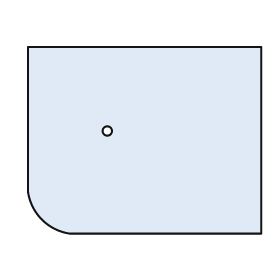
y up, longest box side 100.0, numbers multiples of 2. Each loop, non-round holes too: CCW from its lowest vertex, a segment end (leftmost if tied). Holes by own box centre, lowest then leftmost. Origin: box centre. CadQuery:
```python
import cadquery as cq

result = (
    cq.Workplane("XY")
    .moveTo(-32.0, -40.0)
    .lineTo(50.0, -40.0)
    .lineTo(50.0, 40.0)
    .lineTo(-50.0, 40.0)
    .lineTo(-50.0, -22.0)
    .threePointArc((-44.0, -34.0), (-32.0, -40.0))
    .close()
    .moveTo(-16.0, 4.0)
    .circle(2.0)
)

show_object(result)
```